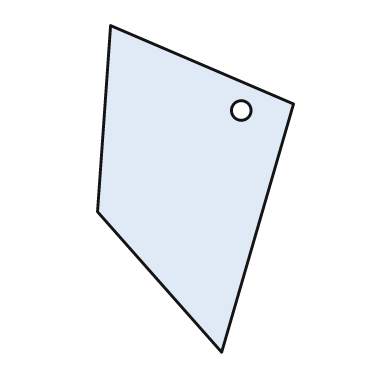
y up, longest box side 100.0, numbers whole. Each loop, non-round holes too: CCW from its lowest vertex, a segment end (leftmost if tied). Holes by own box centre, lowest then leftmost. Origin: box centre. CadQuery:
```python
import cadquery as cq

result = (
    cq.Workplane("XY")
    .moveTo(8.0, -50.0)
    .lineTo(30.0, 26.0)
    .lineTo(-26.0, 50.0)
    .lineTo(-30.0, -7.0)
    .close()
    .moveTo(14.0, 24.0)
    .circle(3.0)
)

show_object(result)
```